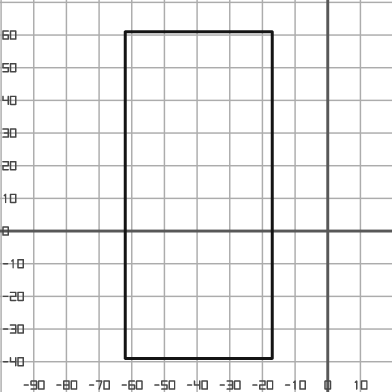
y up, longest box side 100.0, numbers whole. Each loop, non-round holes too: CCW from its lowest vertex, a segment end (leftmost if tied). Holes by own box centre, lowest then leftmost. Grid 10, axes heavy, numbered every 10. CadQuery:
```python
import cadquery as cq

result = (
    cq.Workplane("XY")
    .moveTo(-62.0, -39.0)
    .lineTo(-17.0, -39.0)
    .lineTo(-17.0, 61.0)
    .lineTo(-62.0, 61.0)
    .close()
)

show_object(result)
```